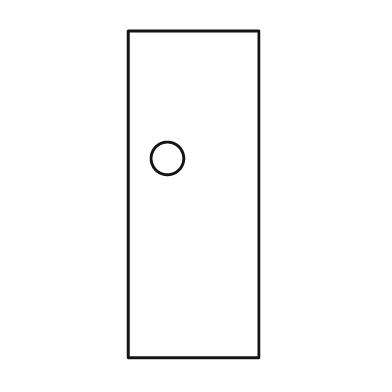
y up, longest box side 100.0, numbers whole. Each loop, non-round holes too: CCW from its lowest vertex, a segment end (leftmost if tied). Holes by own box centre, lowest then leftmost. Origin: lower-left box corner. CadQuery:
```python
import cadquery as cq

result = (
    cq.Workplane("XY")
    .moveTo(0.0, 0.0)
    .lineTo(40.0, 0.0)
    .lineTo(40.0, 100.0)
    .lineTo(0.0, 100.0)
    .close()
    .moveTo(12.0, 61.0)
    .circle(5.0)
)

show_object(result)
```